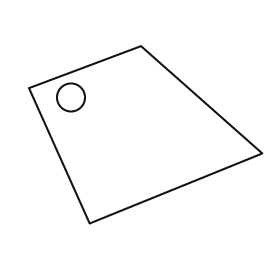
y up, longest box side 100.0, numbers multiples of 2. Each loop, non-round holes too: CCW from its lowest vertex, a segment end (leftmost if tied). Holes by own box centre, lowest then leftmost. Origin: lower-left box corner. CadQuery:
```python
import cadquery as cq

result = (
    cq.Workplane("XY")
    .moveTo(26.0, 0.0)
    .lineTo(100.0, 30.0)
    .lineTo(48.0, 76.0)
    .lineTo(0.0, 58.0)
    .close()
    .moveTo(18.0, 54.0)
    .circle(6.0)
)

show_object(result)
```